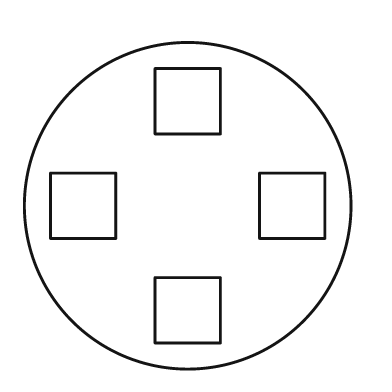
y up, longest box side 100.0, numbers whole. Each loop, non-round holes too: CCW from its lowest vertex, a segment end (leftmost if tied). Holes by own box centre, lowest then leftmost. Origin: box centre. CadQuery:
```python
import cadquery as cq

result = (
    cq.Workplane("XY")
    .moveTo(0.0, 0.0)
    .circle(50.0)
    .moveTo(-10.0, -42.0)
    .lineTo(10.0, -42.0)
    .lineTo(10.0, -22.0)
    .lineTo(-10.0, -22.0)
    .close()
    .moveTo(-42.0, -10.0)
    .lineTo(-22.0, -10.0)
    .lineTo(-22.0, 10.0)
    .lineTo(-42.0, 10.0)
    .close()
    .moveTo(22.0, -10.0)
    .lineTo(42.0, -10.0)
    .lineTo(42.0, 10.0)
    .lineTo(22.0, 10.0)
    .close()
    .moveTo(-10.0, 22.0)
    .lineTo(10.0, 22.0)
    .lineTo(10.0, 42.0)
    .lineTo(-10.0, 42.0)
    .close()
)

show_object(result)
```